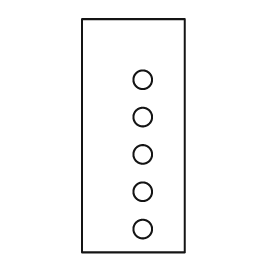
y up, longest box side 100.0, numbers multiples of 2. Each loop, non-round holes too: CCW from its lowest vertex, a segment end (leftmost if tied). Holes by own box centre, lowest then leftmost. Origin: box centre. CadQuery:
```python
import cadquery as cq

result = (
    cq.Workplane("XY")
    .moveTo(-22.0, -50.0)
    .lineTo(22.0, -50.0)
    .lineTo(22.0, 50.0)
    .lineTo(-22.0, 50.0)
    .close()
    .moveTo(4.0, -40.0)
    .circle(4.0)
    .moveTo(4.0, -24.0)
    .circle(4.0)
    .moveTo(4.0, -8.0)
    .circle(4.0)
    .moveTo(4.0, 8.0)
    .circle(4.0)
    .moveTo(4.0, 24.0)
    .circle(4.0)
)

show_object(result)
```